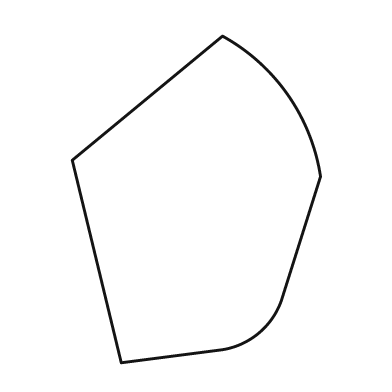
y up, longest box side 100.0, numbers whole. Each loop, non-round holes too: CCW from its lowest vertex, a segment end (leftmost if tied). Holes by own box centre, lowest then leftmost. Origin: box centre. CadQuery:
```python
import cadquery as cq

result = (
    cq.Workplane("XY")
    .moveTo(-23.0, -50.0)
    .lineTo(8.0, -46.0)
    .threePointArc((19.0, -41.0), (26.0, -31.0))
    .lineTo(38.0, 7.0)
    .threePointArc((28.0, 32.0), (8.0, 50.0))
    .lineTo(-38.0, 12.0)
    .close()
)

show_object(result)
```